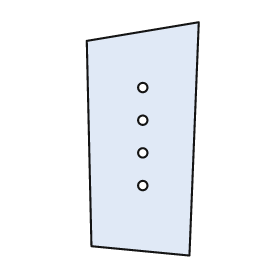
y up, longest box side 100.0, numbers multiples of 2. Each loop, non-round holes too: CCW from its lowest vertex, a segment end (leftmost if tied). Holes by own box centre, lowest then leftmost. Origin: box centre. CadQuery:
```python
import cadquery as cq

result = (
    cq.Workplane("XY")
    .moveTo(20.0, -50.0)
    .lineTo(24.0, 50.0)
    .lineTo(-24.0, 42.0)
    .lineTo(-22.0, -46.0)
    .close()
    .moveTo(0.0, -20.0)
    .circle(2.0)
    .moveTo(0.0, -6.0)
    .circle(2.0)
    .moveTo(0.0, 8.0)
    .circle(2.0)
    .moveTo(0.0, 22.0)
    .circle(2.0)
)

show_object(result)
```